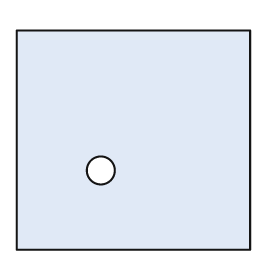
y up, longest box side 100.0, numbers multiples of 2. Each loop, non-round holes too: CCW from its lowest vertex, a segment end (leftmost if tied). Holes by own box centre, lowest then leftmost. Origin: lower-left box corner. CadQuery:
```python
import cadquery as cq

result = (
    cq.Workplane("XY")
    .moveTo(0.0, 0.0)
    .lineTo(100.0, 0.0)
    .lineTo(100.0, 94.0)
    .lineTo(0.0, 94.0)
    .close()
    .moveTo(36.0, 34.0)
    .circle(6.0)
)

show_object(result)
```